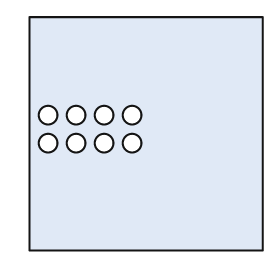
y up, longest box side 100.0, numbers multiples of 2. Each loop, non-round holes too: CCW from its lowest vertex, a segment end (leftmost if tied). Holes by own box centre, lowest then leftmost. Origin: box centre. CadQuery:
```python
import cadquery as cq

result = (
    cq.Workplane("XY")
    .moveTo(-50.0, -50.0)
    .lineTo(50.0, -50.0)
    .lineTo(50.0, 50.0)
    .lineTo(-50.0, 50.0)
    .close()
    .moveTo(-42.0, -4.0)
    .circle(4.0)
    .moveTo(-30.0, -4.0)
    .circle(4.0)
    .moveTo(-18.0, -4.0)
    .circle(4.0)
    .moveTo(-6.0, -4.0)
    .circle(4.0)
    .moveTo(-42.0, 8.0)
    .circle(4.0)
    .moveTo(-30.0, 8.0)
    .circle(4.0)
    .moveTo(-18.0, 8.0)
    .circle(4.0)
    .moveTo(-6.0, 8.0)
    .circle(4.0)
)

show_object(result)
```